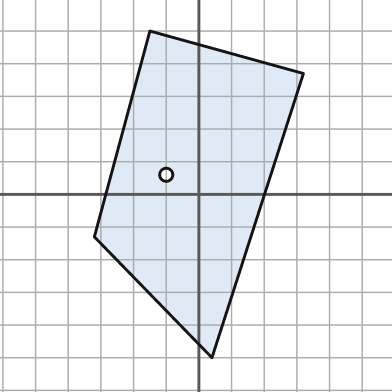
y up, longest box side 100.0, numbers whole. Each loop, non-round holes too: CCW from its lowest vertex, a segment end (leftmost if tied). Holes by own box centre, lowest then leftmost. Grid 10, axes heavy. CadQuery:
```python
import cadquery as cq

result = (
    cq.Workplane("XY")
    .moveTo(4.0, -50.0)
    .lineTo(32.0, 37.0)
    .lineTo(-15.0, 50.0)
    .lineTo(-32.0, -13.0)
    .close()
    .moveTo(-10.0, 6.0)
    .circle(2.0)
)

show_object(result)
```